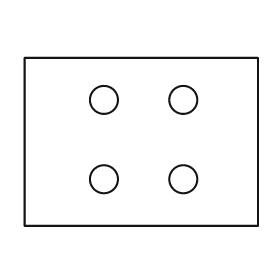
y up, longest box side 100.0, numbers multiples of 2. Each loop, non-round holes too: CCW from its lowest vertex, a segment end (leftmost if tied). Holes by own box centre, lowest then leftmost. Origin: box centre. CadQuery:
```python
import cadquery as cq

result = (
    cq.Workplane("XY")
    .moveTo(-50.0, -36.0)
    .lineTo(50.0, -36.0)
    .lineTo(50.0, 36.0)
    .lineTo(-50.0, 36.0)
    .close()
    .moveTo(-16.0, -16.0)
    .circle(6.0)
    .moveTo(18.0, -16.0)
    .circle(6.0)
    .moveTo(-16.0, 18.0)
    .circle(6.0)
    .moveTo(18.0, 18.0)
    .circle(6.0)
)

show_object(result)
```